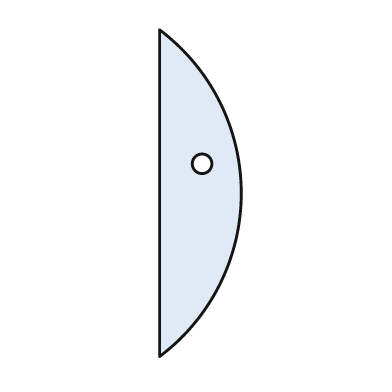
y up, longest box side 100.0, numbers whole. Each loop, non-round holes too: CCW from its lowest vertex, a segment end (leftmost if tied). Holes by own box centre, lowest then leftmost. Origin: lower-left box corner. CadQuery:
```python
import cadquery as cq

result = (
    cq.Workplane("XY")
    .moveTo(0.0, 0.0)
    .threePointArc((25.0, 50.0), (0.0, 100.0))
    .close()
    .moveTo(13.0, 59.0)
    .circle(3.0)
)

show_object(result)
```